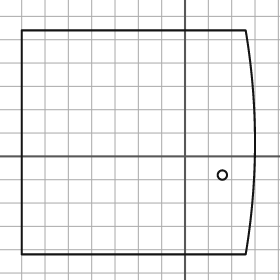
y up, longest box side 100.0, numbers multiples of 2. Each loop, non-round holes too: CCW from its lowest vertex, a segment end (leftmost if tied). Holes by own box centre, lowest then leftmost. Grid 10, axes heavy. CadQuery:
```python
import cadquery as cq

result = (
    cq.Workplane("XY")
    .moveTo(-70.0, -42.0)
    .lineTo(26.0, -42.0)
    .threePointArc((30.0, 6.0), (26.0, 54.0))
    .lineTo(-70.0, 54.0)
    .close()
    .moveTo(16.0, -8.0)
    .circle(2.0)
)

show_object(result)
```